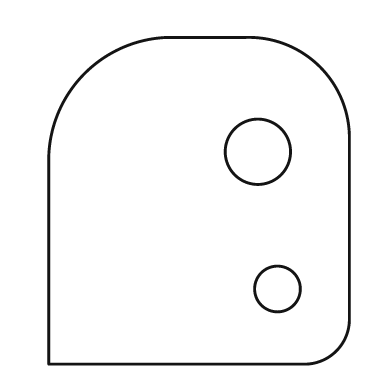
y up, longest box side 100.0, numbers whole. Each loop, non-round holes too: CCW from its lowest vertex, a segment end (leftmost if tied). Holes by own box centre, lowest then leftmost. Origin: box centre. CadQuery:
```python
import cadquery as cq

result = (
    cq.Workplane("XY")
    .moveTo(-46.0, -50.0)
    .lineTo(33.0, -50.0)
    .threePointArc((42.0, -46.0), (46.0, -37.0))
    .lineTo(46.0, 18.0)
    .threePointArc((37.0, 41.0), (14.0, 50.0))
    .lineTo(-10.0, 50.0)
    .threePointArc((-35.0, 39.0), (-46.0, 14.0))
    .close()
    .moveTo(24.0, -27.0)
    .circle(7.0)
    .moveTo(18.0, 15.0)
    .circle(10.0)
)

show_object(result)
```